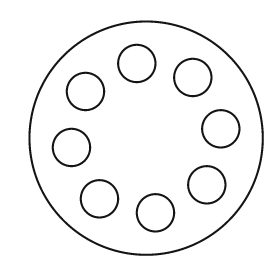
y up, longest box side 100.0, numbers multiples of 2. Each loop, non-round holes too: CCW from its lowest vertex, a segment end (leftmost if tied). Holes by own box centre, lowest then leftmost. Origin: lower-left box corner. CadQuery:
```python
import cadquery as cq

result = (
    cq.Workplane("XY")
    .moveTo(50.0, 50.0)
    .circle(50.0)
    .moveTo(54.0, 18.0)
    .circle(8.0)
    .moveTo(30.0, 24.0)
    .circle(8.0)
    .moveTo(76.0, 30.0)
    .circle(8.0)
    .moveTo(18.0, 46.0)
    .circle(8.0)
    .moveTo(82.0, 54.0)
    .circle(8.0)
    .moveTo(24.0, 70.0)
    .circle(8.0)
    .moveTo(70.0, 76.0)
    .circle(8.0)
    .moveTo(46.0, 82.0)
    .circle(8.0)
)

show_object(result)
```